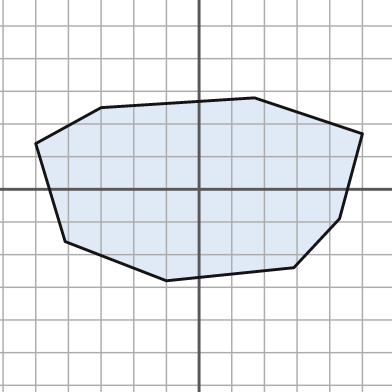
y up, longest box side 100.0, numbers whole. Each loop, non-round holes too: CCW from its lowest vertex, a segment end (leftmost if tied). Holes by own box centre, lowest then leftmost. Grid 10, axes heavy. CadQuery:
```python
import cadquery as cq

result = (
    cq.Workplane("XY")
    .moveTo(-10.0, -28.0)
    .lineTo(29.0, -24.0)
    .lineTo(43.0, -9.0)
    .lineTo(50.0, 17.0)
    .lineTo(17.0, 28.0)
    .lineTo(-30.0, 25.0)
    .lineTo(-50.0, 14.0)
    .lineTo(-41.0, -16.0)
    .close()
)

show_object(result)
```